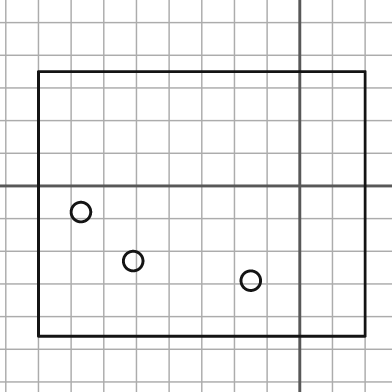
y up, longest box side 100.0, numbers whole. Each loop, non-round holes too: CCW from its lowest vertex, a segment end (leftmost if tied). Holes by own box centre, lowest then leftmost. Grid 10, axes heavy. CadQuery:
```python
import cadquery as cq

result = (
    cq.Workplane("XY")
    .moveTo(-80.0, -46.0)
    .lineTo(20.0, -46.0)
    .lineTo(20.0, 35.0)
    .lineTo(-80.0, 35.0)
    .close()
    .moveTo(-15.0, -29.0)
    .circle(3.0)
    .moveTo(-51.0, -23.0)
    .circle(3.0)
    .moveTo(-67.0, -8.0)
    .circle(3.0)
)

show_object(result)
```